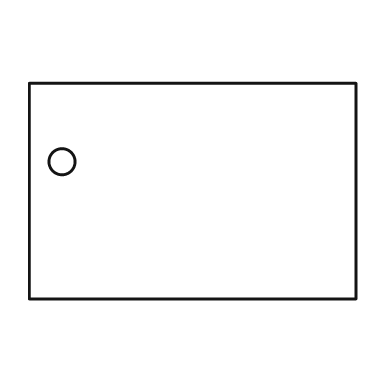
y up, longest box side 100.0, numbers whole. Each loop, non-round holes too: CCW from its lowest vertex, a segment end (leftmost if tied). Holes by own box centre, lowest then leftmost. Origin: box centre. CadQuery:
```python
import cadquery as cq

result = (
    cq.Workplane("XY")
    .moveTo(-50.0, -33.0)
    .lineTo(50.0, -33.0)
    .lineTo(50.0, 33.0)
    .lineTo(-50.0, 33.0)
    .close()
    .moveTo(-40.0, 9.0)
    .circle(4.0)
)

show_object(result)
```